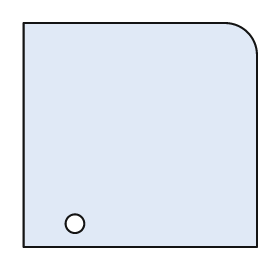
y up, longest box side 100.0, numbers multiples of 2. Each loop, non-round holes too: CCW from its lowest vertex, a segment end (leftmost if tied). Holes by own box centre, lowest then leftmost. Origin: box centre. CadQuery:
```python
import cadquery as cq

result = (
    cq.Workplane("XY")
    .moveTo(-50.0, -48.0)
    .lineTo(50.0, -48.0)
    .lineTo(50.0, 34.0)
    .threePointArc((46.0, 44.0), (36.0, 48.0))
    .lineTo(-50.0, 48.0)
    .close()
    .moveTo(-28.0, -38.0)
    .circle(4.0)
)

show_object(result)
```